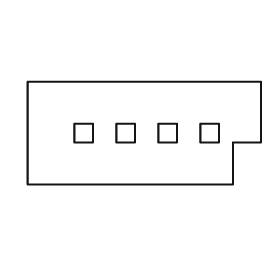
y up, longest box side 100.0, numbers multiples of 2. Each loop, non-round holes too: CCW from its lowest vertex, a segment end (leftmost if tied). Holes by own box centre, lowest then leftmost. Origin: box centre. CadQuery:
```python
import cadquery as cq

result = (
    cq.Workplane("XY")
    .moveTo(-50.0, -22.0)
    .lineTo(38.0, -22.0)
    .lineTo(38.0, -4.0)
    .lineTo(50.0, -4.0)
    .lineTo(50.0, 22.0)
    .lineTo(-50.0, 22.0)
    .close()
    .moveTo(-30.0, -4.0)
    .lineTo(-22.0, -4.0)
    .lineTo(-22.0, 4.0)
    .lineTo(-30.0, 4.0)
    .close()
    .moveTo(-12.0, -4.0)
    .lineTo(-4.0, -4.0)
    .lineTo(-4.0, 4.0)
    .lineTo(-12.0, 4.0)
    .close()
    .moveTo(6.0, -4.0)
    .lineTo(14.0, -4.0)
    .lineTo(14.0, 4.0)
    .lineTo(6.0, 4.0)
    .close()
    .moveTo(24.0, -4.0)
    .lineTo(32.0, -4.0)
    .lineTo(32.0, 4.0)
    .lineTo(24.0, 4.0)
    .close()
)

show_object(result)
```